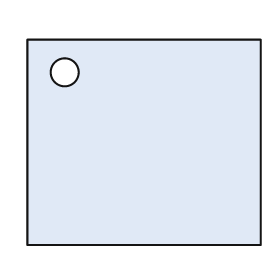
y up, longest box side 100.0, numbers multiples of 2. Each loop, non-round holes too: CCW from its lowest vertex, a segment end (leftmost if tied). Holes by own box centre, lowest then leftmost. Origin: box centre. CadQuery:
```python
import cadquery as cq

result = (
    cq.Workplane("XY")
    .moveTo(-50.0, -44.0)
    .lineTo(50.0, -44.0)
    .lineTo(50.0, 44.0)
    .lineTo(-50.0, 44.0)
    .close()
    .moveTo(-34.0, 30.0)
    .circle(6.0)
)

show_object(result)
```